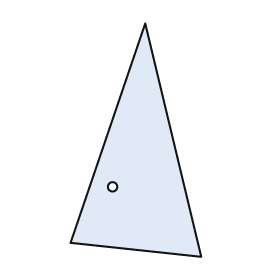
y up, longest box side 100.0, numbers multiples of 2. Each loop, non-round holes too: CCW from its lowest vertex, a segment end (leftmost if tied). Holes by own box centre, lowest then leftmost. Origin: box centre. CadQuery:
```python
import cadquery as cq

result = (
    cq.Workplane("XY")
    .moveTo(28.0, -50.0)
    .lineTo(4.0, 50.0)
    .lineTo(-28.0, -44.0)
    .close()
    .moveTo(-10.0, -20.0)
    .circle(2.0)
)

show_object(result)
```